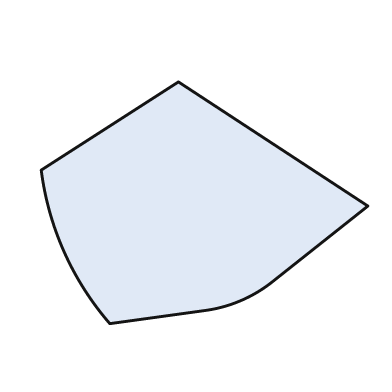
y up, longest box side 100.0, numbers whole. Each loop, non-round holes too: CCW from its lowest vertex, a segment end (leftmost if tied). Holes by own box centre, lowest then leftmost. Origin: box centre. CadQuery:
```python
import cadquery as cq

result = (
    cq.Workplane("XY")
    .moveTo(-29.0, -37.0)
    .lineTo(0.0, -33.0)
    .threePointArc((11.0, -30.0), (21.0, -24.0))
    .lineTo(50.0, -1.0)
    .lineTo(-8.0, 37.0)
    .lineTo(-50.0, 10.0)
    .threePointArc((-43.0, -15.0), (-29.0, -37.0))
    .close()
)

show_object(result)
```